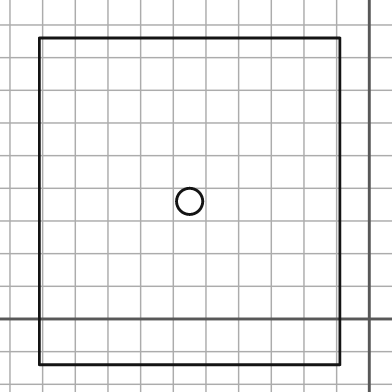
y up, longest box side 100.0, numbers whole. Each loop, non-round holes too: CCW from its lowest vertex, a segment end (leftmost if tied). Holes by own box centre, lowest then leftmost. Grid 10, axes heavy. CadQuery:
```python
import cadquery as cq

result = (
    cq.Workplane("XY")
    .moveTo(-101.0, -14.0)
    .lineTo(-9.0, -14.0)
    .lineTo(-9.0, 86.0)
    .lineTo(-101.0, 86.0)
    .close()
    .moveTo(-55.0, 36.0)
    .circle(4.0)
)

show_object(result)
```